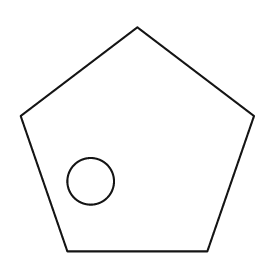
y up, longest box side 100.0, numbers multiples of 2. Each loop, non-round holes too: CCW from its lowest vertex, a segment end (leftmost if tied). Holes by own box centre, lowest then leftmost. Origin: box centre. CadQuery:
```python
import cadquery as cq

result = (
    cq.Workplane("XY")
    .moveTo(-30.0, -48.0)
    .lineTo(30.0, -48.0)
    .lineTo(50.0, 10.0)
    .lineTo(0.0, 48.0)
    .lineTo(-50.0, 10.0)
    .close()
    .moveTo(-20.0, -18.0)
    .circle(10.0)
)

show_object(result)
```